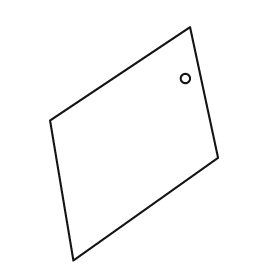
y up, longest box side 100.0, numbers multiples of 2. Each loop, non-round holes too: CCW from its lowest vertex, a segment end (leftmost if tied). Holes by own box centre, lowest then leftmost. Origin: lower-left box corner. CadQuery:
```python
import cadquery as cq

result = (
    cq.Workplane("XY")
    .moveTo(10.0, 0.0)
    .lineTo(72.0, 44.0)
    .lineTo(60.0, 100.0)
    .lineTo(0.0, 60.0)
    .close()
    .moveTo(58.0, 78.0)
    .circle(2.0)
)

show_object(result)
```